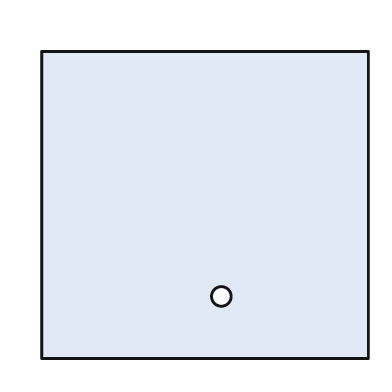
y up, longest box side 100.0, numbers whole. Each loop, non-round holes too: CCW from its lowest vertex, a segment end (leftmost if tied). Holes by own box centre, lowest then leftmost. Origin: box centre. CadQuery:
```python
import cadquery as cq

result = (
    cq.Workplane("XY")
    .moveTo(-50.0, -47.0)
    .lineTo(50.0, -47.0)
    .lineTo(50.0, 47.0)
    .lineTo(-50.0, 47.0)
    .close()
    .moveTo(5.0, -28.0)
    .circle(3.0)
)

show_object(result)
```